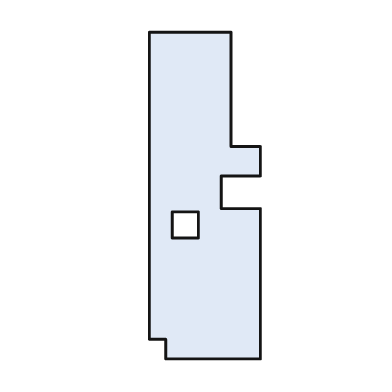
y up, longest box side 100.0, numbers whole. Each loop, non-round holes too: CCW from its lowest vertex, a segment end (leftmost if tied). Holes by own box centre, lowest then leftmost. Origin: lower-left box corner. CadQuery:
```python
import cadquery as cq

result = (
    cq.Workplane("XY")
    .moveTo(5.0, 0.0)
    .lineTo(34.0, 0.0)
    .lineTo(34.0, 46.0)
    .lineTo(22.0, 46.0)
    .lineTo(22.0, 56.0)
    .lineTo(34.0, 56.0)
    .lineTo(34.0, 65.0)
    .lineTo(25.0, 65.0)
    .lineTo(25.0, 100.0)
    .lineTo(0.0, 100.0)
    .lineTo(0.0, 6.0)
    .lineTo(5.0, 6.0)
    .close()
    .moveTo(7.0, 37.0)
    .lineTo(15.0, 37.0)
    .lineTo(15.0, 45.0)
    .lineTo(7.0, 45.0)
    .close()
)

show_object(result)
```